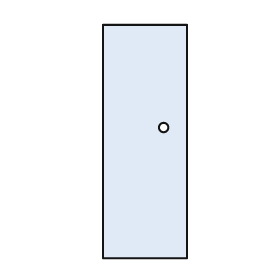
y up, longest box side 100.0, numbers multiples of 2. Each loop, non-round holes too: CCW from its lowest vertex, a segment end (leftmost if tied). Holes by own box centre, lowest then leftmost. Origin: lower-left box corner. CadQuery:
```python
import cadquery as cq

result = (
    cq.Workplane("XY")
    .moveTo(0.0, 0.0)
    .lineTo(36.0, 0.0)
    .lineTo(36.0, 100.0)
    .lineTo(0.0, 100.0)
    .close()
    .moveTo(26.0, 56.0)
    .circle(2.0)
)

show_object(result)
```